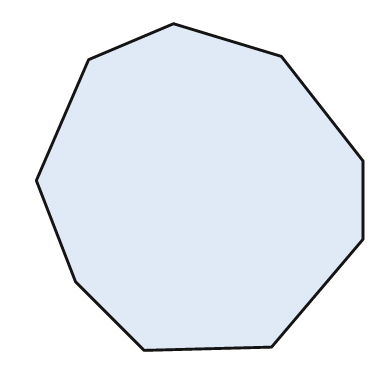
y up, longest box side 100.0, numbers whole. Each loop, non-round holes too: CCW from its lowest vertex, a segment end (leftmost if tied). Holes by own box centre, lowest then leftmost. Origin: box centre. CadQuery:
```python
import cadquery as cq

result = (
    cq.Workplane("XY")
    .moveTo(-17.0, -50.0)
    .lineTo(22.0, -49.0)
    .lineTo(50.0, -16.0)
    .lineTo(50.0, 8.0)
    .lineTo(25.0, 40.0)
    .lineTo(-8.0, 50.0)
    .lineTo(-34.0, 39.0)
    .lineTo(-50.0, 2.0)
    .lineTo(-38.0, -29.0)
    .close()
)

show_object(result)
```